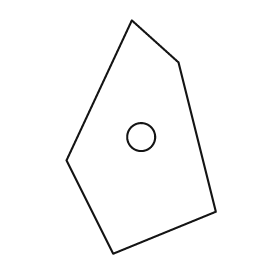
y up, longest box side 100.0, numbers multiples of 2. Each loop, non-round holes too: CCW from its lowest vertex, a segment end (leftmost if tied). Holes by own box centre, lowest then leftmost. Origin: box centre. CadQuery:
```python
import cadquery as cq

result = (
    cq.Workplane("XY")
    .moveTo(-12.0, -50.0)
    .lineTo(32.0, -32.0)
    .lineTo(16.0, 32.0)
    .lineTo(-4.0, 50.0)
    .lineTo(-32.0, -10.0)
    .close()
    .moveTo(0.0, 0.0)
    .circle(6.0)
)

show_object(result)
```